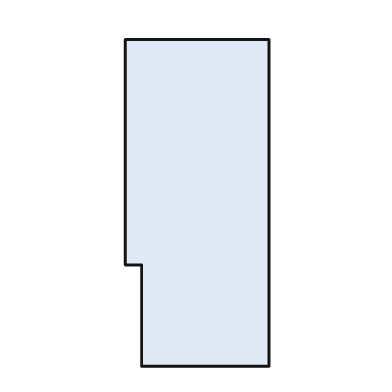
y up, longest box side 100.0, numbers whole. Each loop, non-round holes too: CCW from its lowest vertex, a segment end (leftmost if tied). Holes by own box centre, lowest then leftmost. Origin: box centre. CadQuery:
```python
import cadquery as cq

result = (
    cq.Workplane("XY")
    .moveTo(-17.0, -50.0)
    .lineTo(22.0, -50.0)
    .lineTo(22.0, 50.0)
    .lineTo(-22.0, 50.0)
    .lineTo(-22.0, -19.0)
    .lineTo(-17.0, -19.0)
    .close()
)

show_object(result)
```